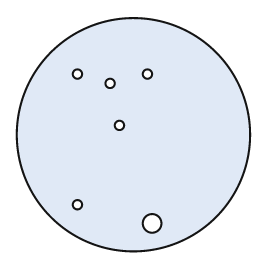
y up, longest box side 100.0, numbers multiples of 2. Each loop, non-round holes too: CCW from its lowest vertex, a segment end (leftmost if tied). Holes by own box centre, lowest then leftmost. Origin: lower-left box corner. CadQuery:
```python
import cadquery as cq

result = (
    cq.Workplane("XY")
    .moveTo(50.0, 50.0)
    .circle(50.0)
    .moveTo(58.0, 12.0)
    .circle(4.0)
    .moveTo(26.0, 20.0)
    .circle(2.0)
    .moveTo(44.0, 54.0)
    .circle(2.0)
    .moveTo(40.0, 72.0)
    .circle(2.0)
    .moveTo(26.0, 76.0)
    .circle(2.0)
    .moveTo(56.0, 76.0)
    .circle(2.0)
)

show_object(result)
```